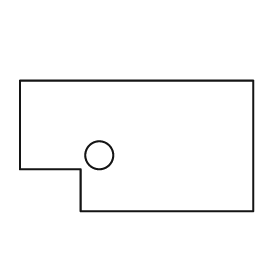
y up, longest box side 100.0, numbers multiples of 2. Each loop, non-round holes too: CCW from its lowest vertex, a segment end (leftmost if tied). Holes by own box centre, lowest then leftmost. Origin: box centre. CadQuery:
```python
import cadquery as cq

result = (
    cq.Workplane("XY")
    .moveTo(-24.0, -28.0)
    .lineTo(50.0, -28.0)
    .lineTo(50.0, 28.0)
    .lineTo(-50.0, 28.0)
    .lineTo(-50.0, -10.0)
    .lineTo(-24.0, -10.0)
    .close()
    .moveTo(-16.0, -4.0)
    .circle(6.0)
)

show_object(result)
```